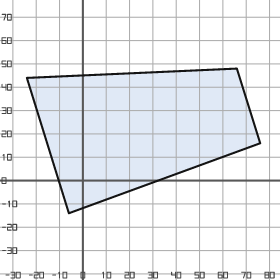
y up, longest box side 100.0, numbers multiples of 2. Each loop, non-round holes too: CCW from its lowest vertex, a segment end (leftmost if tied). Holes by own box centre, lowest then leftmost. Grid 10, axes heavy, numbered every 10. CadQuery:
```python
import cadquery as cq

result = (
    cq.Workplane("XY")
    .moveTo(-6.0, -14.0)
    .lineTo(76.0, 16.0)
    .lineTo(66.0, 48.0)
    .lineTo(-24.0, 44.0)
    .close()
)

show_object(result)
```